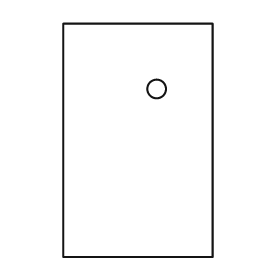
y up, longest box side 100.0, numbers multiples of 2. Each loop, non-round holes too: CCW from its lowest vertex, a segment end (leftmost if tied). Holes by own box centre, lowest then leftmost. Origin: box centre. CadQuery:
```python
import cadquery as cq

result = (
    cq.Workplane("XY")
    .moveTo(-32.0, -50.0)
    .lineTo(32.0, -50.0)
    .lineTo(32.0, 50.0)
    .lineTo(-32.0, 50.0)
    .close()
    .moveTo(8.0, 22.0)
    .circle(4.0)
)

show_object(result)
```